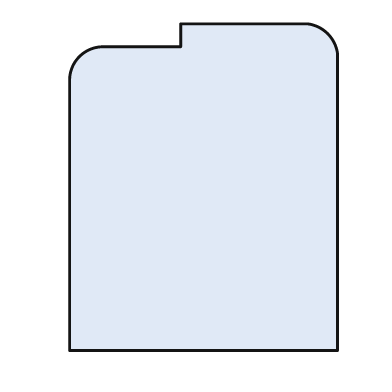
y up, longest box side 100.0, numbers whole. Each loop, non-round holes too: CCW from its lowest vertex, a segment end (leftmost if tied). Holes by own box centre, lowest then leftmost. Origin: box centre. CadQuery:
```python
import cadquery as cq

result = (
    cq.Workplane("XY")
    .moveTo(-41.0, -50.0)
    .lineTo(41.0, -50.0)
    .lineTo(41.0, 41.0)
    .threePointArc((38.0, 47.0), (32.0, 50.0))
    .lineTo(-7.0, 50.0)
    .lineTo(-7.0, 43.0)
    .lineTo(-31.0, 43.0)
    .threePointArc((-38.0, 40.0), (-41.0, 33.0))
    .close()
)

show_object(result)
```